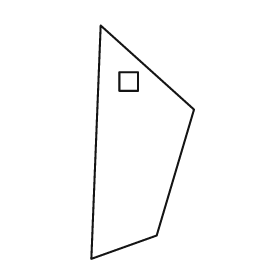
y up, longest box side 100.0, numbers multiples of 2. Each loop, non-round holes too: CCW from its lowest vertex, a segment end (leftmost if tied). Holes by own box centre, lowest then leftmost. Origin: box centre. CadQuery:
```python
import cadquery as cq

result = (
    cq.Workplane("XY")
    .moveTo(-22.0, -50.0)
    .lineTo(6.0, -40.0)
    .lineTo(22.0, 14.0)
    .lineTo(-18.0, 50.0)
    .close()
    .moveTo(-10.0, 22.0)
    .lineTo(-2.0, 22.0)
    .lineTo(-2.0, 30.0)
    .lineTo(-10.0, 30.0)
    .close()
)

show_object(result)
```